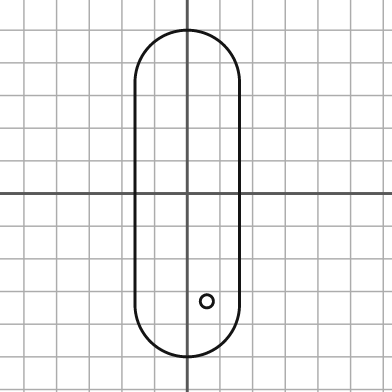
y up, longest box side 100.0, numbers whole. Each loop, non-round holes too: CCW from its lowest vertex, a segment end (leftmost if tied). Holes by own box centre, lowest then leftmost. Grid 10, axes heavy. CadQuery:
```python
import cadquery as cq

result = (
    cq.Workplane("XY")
    .moveTo(-16.0, -34.0)
    .threePointArc((0.0, -50.0), (16.0, -34.0))
    .lineTo(16.0, 34.0)
    .threePointArc((0.0, 50.0), (-16.0, 34.0))
    .close()
    .moveTo(6.0, -33.0)
    .circle(2.0)
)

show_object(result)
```